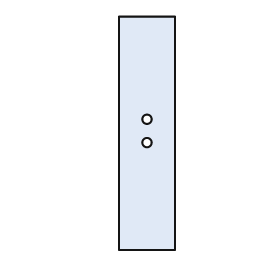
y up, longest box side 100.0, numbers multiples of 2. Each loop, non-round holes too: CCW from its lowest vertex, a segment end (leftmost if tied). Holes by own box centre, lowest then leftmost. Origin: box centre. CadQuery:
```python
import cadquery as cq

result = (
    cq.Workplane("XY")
    .moveTo(-12.0, -50.0)
    .lineTo(12.0, -50.0)
    .lineTo(12.0, 50.0)
    .lineTo(-12.0, 50.0)
    .close()
    .moveTo(0.0, -4.0)
    .circle(2.0)
    .moveTo(0.0, 6.0)
    .circle(2.0)
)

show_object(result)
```